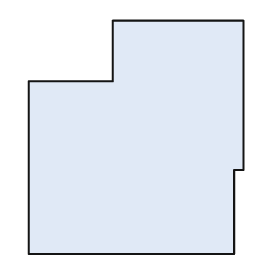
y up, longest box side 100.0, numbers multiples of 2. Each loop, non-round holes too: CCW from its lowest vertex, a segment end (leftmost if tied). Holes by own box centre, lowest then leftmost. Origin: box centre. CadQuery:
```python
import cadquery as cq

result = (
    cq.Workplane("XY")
    .moveTo(-46.0, -50.0)
    .lineTo(42.0, -50.0)
    .lineTo(42.0, -14.0)
    .lineTo(46.0, -14.0)
    .lineTo(46.0, 50.0)
    .lineTo(-10.0, 50.0)
    .lineTo(-10.0, 24.0)
    .lineTo(-46.0, 24.0)
    .close()
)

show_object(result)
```